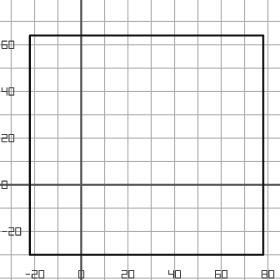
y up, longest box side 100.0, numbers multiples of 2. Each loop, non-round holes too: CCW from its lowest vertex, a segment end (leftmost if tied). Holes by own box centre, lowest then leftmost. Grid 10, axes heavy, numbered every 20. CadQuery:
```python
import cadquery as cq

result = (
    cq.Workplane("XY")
    .moveTo(-22.0, -30.0)
    .lineTo(78.0, -30.0)
    .lineTo(78.0, 64.0)
    .lineTo(-22.0, 64.0)
    .close()
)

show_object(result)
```